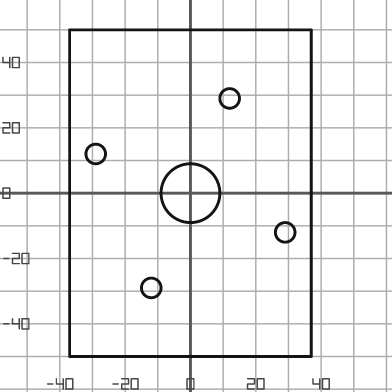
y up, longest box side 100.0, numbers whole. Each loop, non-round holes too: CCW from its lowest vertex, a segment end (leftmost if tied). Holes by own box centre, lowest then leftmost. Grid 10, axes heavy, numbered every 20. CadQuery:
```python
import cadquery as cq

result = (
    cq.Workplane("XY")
    .moveTo(-37.0, -50.0)
    .lineTo(37.0, -50.0)
    .lineTo(37.0, 50.0)
    .lineTo(-37.0, 50.0)
    .close()
    .moveTo(-12.0, -29.0)
    .circle(3.0)
    .moveTo(29.0, -12.0)
    .circle(3.0)
    .moveTo(0.0, 0.0)
    .circle(9.0)
    .moveTo(-29.0, 12.0)
    .circle(3.0)
    .moveTo(12.0, 29.0)
    .circle(3.0)
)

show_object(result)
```